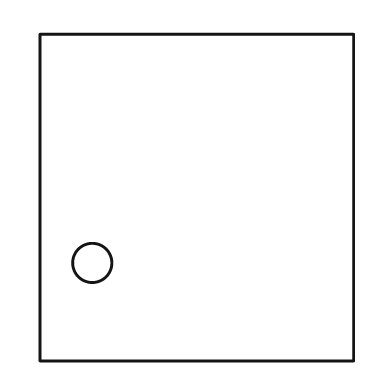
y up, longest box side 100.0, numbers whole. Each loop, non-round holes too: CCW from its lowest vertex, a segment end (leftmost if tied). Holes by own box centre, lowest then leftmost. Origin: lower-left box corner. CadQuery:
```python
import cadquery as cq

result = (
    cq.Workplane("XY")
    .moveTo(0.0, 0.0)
    .lineTo(96.0, 0.0)
    .lineTo(96.0, 100.0)
    .lineTo(0.0, 100.0)
    .close()
    .moveTo(16.0, 30.0)
    .circle(6.0)
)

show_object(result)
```